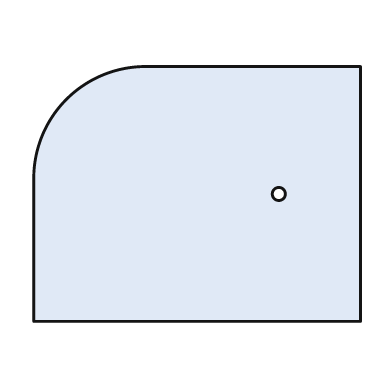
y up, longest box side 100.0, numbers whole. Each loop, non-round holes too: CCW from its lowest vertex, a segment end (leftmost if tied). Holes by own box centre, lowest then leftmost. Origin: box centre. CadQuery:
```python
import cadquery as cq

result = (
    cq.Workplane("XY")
    .moveTo(-50.0, -39.0)
    .lineTo(50.0, -39.0)
    .lineTo(50.0, 39.0)
    .lineTo(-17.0, 39.0)
    .threePointArc((-40.0, 29.0), (-50.0, 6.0))
    .close()
    .moveTo(25.0, 0.0)
    .circle(2.0)
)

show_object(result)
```